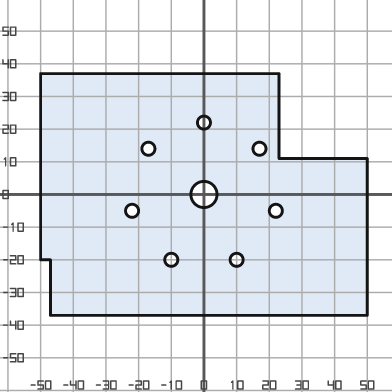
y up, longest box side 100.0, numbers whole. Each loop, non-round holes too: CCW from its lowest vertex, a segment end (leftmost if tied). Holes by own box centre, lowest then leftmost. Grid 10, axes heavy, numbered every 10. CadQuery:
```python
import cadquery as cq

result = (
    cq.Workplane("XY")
    .moveTo(-47.0, -37.0)
    .lineTo(50.0, -37.0)
    .lineTo(50.0, 11.0)
    .lineTo(23.0, 11.0)
    .lineTo(23.0, 37.0)
    .lineTo(-50.0, 37.0)
    .lineTo(-50.0, -20.0)
    .lineTo(-47.0, -20.0)
    .close()
    .moveTo(-10.0, -20.0)
    .circle(2.0)
    .moveTo(10.0, -20.0)
    .circle(2.0)
    .moveTo(-22.0, -5.0)
    .circle(2.0)
    .moveTo(22.0, -5.0)
    .circle(2.0)
    .moveTo(0.0, 0.0)
    .circle(4.0)
    .moveTo(-17.0, 14.0)
    .circle(2.0)
    .moveTo(17.0, 14.0)
    .circle(2.0)
    .moveTo(0.0, 22.0)
    .circle(2.0)
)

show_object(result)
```